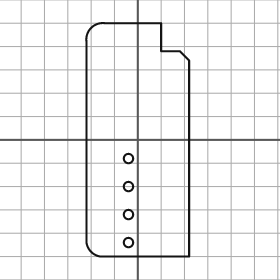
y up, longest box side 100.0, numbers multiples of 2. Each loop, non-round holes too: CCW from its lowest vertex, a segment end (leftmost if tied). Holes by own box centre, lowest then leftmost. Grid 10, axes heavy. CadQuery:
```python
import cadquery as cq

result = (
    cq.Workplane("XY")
    .moveTo(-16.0, -50.0)
    .lineTo(22.0, -50.0)
    .lineTo(22.0, 34.0)
    .lineTo(18.0, 38.0)
    .lineTo(10.0, 38.0)
    .lineTo(10.0, 50.0)
    .lineTo(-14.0, 50.0)
    .threePointArc((-20.0, 48.0), (-22.0, 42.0))
    .lineTo(-22.0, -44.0)
    .threePointArc((-20.0, -48.0), (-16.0, -50.0))
    .close()
    .moveTo(-4.0, -44.0)
    .circle(2.0)
    .moveTo(-4.0, -32.0)
    .circle(2.0)
    .moveTo(-4.0, -20.0)
    .circle(2.0)
    .moveTo(-4.0, -8.0)
    .circle(2.0)
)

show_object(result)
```